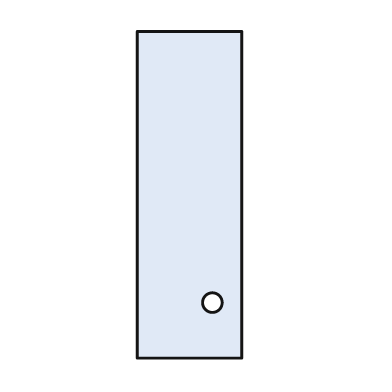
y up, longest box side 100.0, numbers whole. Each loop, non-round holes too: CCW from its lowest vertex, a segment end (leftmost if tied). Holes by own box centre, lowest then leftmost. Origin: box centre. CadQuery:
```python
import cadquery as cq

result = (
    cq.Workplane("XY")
    .moveTo(-16.0, -50.0)
    .lineTo(16.0, -50.0)
    .lineTo(16.0, 50.0)
    .lineTo(-16.0, 50.0)
    .close()
    .moveTo(7.0, -33.0)
    .circle(3.0)
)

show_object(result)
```